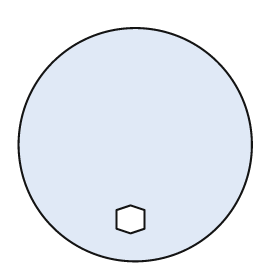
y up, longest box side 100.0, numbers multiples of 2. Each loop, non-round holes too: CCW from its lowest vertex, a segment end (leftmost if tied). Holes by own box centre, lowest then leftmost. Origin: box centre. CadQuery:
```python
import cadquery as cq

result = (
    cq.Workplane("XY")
    .moveTo(0.0, 0.0)
    .circle(50.0)
    .moveTo(-2.0, -38.0)
    .lineTo(4.0, -36.0)
    .lineTo(4.0, -28.0)
    .lineTo(-2.0, -26.0)
    .lineTo(-8.0, -28.0)
    .lineTo(-8.0, -36.0)
    .close()
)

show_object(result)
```